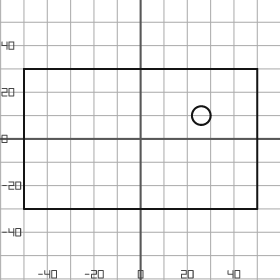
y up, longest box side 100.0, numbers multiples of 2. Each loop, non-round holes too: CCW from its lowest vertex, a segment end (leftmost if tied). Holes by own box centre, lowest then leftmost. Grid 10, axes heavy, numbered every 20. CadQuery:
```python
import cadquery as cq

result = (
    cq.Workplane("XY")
    .moveTo(-50.0, -30.0)
    .lineTo(50.0, -30.0)
    .lineTo(50.0, 30.0)
    .lineTo(-50.0, 30.0)
    .close()
    .moveTo(26.0, 10.0)
    .circle(4.0)
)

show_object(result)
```